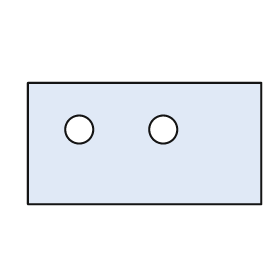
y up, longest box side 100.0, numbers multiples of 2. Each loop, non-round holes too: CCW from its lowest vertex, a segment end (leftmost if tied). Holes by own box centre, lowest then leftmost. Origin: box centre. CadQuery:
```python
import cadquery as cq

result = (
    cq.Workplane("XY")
    .moveTo(-50.0, -26.0)
    .lineTo(50.0, -26.0)
    .lineTo(50.0, 26.0)
    .lineTo(-50.0, 26.0)
    .close()
    .moveTo(-28.0, 6.0)
    .circle(6.0)
    .moveTo(8.0, 6.0)
    .circle(6.0)
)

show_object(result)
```